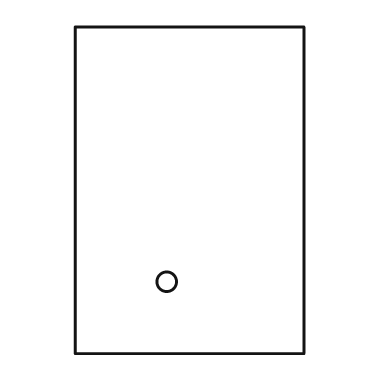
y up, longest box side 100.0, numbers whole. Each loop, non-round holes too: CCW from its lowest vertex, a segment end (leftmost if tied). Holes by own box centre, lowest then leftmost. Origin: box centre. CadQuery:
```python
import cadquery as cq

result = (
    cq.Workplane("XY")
    .moveTo(-35.0, -50.0)
    .lineTo(35.0, -50.0)
    .lineTo(35.0, 50.0)
    .lineTo(-35.0, 50.0)
    .close()
    .moveTo(-7.0, -28.0)
    .circle(3.0)
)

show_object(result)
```